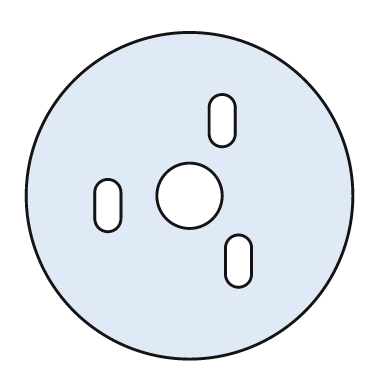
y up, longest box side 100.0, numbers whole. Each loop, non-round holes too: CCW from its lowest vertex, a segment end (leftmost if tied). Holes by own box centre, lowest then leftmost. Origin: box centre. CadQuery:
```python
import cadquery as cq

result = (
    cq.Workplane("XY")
    .moveTo(0.0, 0.0)
    .circle(50.0)
    .moveTo(11.0, -24.0)
    .threePointArc((15.0, -28.0), (19.0, -24.0))
    .lineTo(19.0, -16.0)
    .threePointArc((15.0, -12.0), (11.0, -16.0))
    .close()
    .moveTo(-29.0, -7.0)
    .threePointArc((-25.0, -11.0), (-21.0, -7.0))
    .lineTo(-21.0, 1.0)
    .threePointArc((-25.0, 5.0), (-29.0, 1.0))
    .close()
    .moveTo(0.0, 0.0)
    .circle(10.0)
    .moveTo(6.0, 19.0)
    .threePointArc((10.0, 15.0), (14.0, 19.0))
    .lineTo(14.0, 27.0)
    .threePointArc((10.0, 31.0), (6.0, 27.0))
    .close()
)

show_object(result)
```